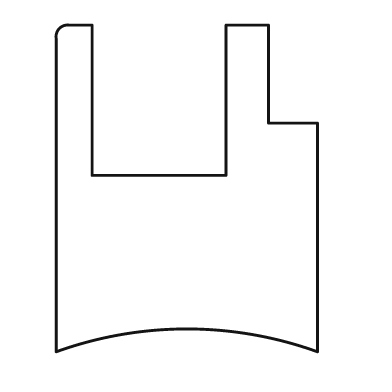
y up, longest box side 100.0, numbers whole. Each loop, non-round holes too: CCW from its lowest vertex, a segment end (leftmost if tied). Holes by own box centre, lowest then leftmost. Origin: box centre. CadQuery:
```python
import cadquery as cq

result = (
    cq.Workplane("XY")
    .moveTo(-40.0, -50.0)
    .threePointArc((0.0, -43.0), (40.0, -50.0))
    .lineTo(40.0, 20.0)
    .lineTo(25.0, 20.0)
    .lineTo(25.0, 50.0)
    .lineTo(12.0, 50.0)
    .lineTo(12.0, 4.0)
    .lineTo(-29.0, 4.0)
    .lineTo(-29.0, 50.0)
    .lineTo(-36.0, 50.0)
    .threePointArc((-39.0, 49.0), (-40.0, 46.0))
    .close()
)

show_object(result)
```